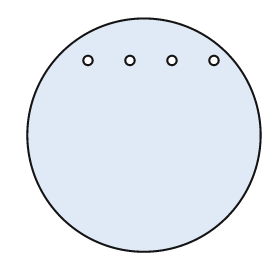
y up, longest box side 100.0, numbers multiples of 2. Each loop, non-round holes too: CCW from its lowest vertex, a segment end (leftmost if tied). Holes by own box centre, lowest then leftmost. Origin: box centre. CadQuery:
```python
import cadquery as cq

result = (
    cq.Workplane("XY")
    .moveTo(0.0, 0.0)
    .circle(50.0)
    .moveTo(-24.0, 32.0)
    .circle(2.0)
    .moveTo(-6.0, 32.0)
    .circle(2.0)
    .moveTo(12.0, 32.0)
    .circle(2.0)
    .moveTo(30.0, 32.0)
    .circle(2.0)
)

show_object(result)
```